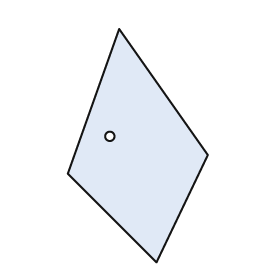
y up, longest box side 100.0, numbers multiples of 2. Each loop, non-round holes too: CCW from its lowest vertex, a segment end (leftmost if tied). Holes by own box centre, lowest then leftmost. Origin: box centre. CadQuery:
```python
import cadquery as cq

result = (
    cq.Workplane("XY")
    .moveTo(8.0, -50.0)
    .lineTo(30.0, -4.0)
    .lineTo(-8.0, 50.0)
    .lineTo(-30.0, -12.0)
    .close()
    .moveTo(-12.0, 4.0)
    .circle(2.0)
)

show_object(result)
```